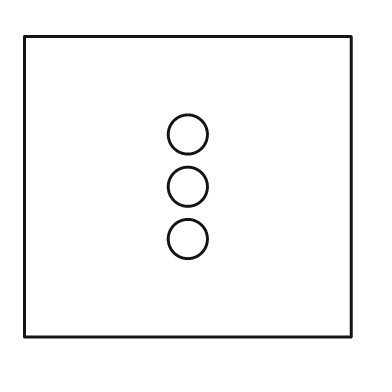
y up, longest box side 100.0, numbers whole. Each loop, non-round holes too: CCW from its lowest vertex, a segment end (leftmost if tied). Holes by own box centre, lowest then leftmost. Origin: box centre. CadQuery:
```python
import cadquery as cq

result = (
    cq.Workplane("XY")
    .moveTo(-50.0, -46.0)
    .lineTo(50.0, -46.0)
    .lineTo(50.0, 46.0)
    .lineTo(-50.0, 46.0)
    .close()
    .moveTo(0.0, -16.0)
    .circle(6.0)
    .moveTo(0.0, 0.0)
    .circle(6.0)
    .moveTo(0.0, 16.0)
    .circle(6.0)
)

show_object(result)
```